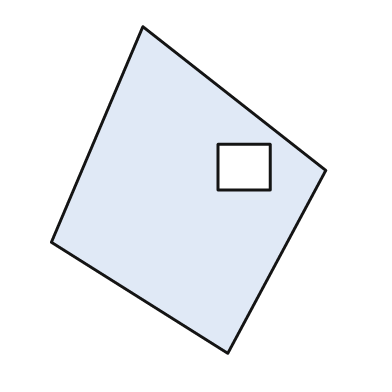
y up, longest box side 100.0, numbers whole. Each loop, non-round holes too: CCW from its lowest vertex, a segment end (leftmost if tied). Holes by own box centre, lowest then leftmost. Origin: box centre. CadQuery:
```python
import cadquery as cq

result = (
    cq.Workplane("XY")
    .moveTo(12.0, -50.0)
    .lineTo(42.0, 6.0)
    .lineTo(-14.0, 50.0)
    .lineTo(-42.0, -16.0)
    .close()
    .moveTo(9.0, 0.0)
    .lineTo(25.0, 0.0)
    .lineTo(25.0, 14.0)
    .lineTo(9.0, 14.0)
    .close()
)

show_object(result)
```